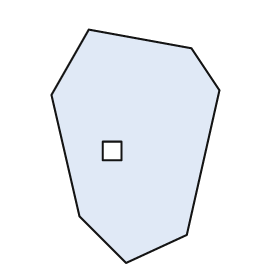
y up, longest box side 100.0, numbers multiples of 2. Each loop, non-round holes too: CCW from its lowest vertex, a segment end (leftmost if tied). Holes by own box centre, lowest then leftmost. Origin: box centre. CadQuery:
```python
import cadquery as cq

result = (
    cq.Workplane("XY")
    .moveTo(-4.0, -50.0)
    .lineTo(22.0, -38.0)
    .lineTo(36.0, 24.0)
    .lineTo(24.0, 42.0)
    .lineTo(-20.0, 50.0)
    .lineTo(-36.0, 22.0)
    .lineTo(-24.0, -30.0)
    .close()
    .moveTo(-14.0, -6.0)
    .lineTo(-6.0, -6.0)
    .lineTo(-6.0, 2.0)
    .lineTo(-14.0, 2.0)
    .close()
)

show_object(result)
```